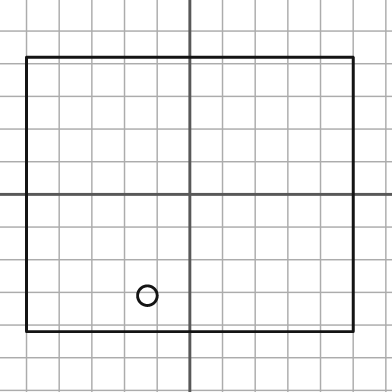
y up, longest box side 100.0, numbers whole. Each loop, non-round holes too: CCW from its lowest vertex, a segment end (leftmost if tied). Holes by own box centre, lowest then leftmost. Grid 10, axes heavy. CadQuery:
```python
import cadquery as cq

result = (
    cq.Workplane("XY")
    .moveTo(-50.0, -42.0)
    .lineTo(50.0, -42.0)
    .lineTo(50.0, 42.0)
    .lineTo(-50.0, 42.0)
    .close()
    .moveTo(-13.0, -31.0)
    .circle(3.0)
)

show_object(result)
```